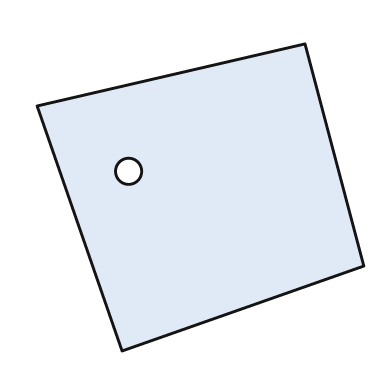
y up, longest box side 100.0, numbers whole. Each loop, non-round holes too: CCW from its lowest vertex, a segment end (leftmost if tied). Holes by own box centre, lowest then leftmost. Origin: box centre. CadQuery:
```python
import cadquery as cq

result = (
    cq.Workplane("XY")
    .moveTo(-24.0, -47.0)
    .lineTo(50.0, -21.0)
    .lineTo(32.0, 47.0)
    .lineTo(-50.0, 28.0)
    .close()
    .moveTo(-22.0, 8.0)
    .circle(4.0)
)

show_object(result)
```